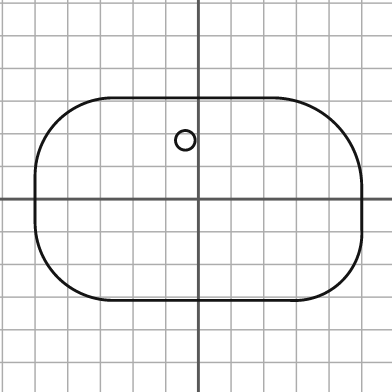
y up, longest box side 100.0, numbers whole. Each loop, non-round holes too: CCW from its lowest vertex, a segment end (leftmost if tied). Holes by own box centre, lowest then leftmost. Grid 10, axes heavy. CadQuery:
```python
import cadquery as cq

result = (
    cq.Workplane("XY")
    .moveTo(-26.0, -31.0)
    .lineTo(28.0, -31.0)
    .threePointArc((44.0, -25.0), (50.0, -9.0))
    .lineTo(50.0, 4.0)
    .threePointArc((42.0, 23.0), (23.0, 31.0))
    .lineTo(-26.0, 31.0)
    .threePointArc((-43.0, 24.0), (-50.0, 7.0))
    .lineTo(-50.0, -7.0)
    .threePointArc((-43.0, -24.0), (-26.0, -31.0))
    .close()
    .moveTo(-4.0, 18.0)
    .circle(3.0)
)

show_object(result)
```